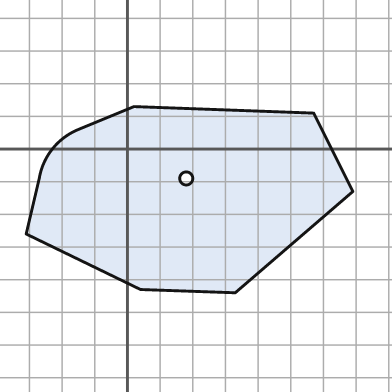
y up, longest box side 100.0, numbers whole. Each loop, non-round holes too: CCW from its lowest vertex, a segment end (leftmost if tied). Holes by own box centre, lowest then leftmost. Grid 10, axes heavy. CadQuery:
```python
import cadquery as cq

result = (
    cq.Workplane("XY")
    .moveTo(33.0, -44.0)
    .lineTo(69.0, -13.0)
    .lineTo(57.0, 11.0)
    .lineTo(2.0, 13.0)
    .lineTo(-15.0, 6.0)
    .threePointArc((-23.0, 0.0), (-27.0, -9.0))
    .lineTo(-31.0, -26.0)
    .lineTo(4.0, -43.0)
    .close()
    .moveTo(18.0, -9.0)
    .circle(2.0)
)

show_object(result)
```